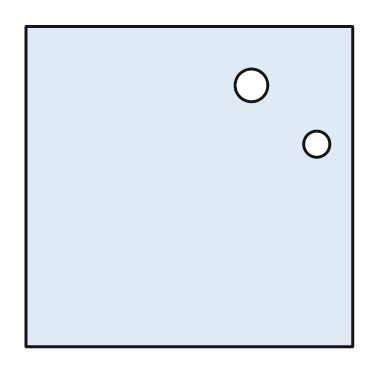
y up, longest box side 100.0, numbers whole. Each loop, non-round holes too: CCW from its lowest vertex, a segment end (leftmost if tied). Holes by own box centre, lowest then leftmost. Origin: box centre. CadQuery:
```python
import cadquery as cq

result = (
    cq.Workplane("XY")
    .moveTo(-50.0, -49.0)
    .lineTo(50.0, -49.0)
    .lineTo(50.0, 49.0)
    .lineTo(-50.0, 49.0)
    .close()
    .moveTo(39.0, 13.0)
    .circle(4.0)
    .moveTo(19.0, 31.0)
    .circle(5.0)
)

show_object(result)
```